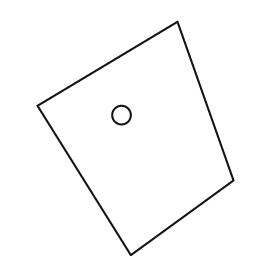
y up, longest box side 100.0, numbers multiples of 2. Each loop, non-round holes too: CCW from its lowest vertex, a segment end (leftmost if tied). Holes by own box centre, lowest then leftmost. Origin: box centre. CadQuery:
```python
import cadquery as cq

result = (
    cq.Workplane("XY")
    .moveTo(-2.0, -50.0)
    .lineTo(42.0, -18.0)
    .lineTo(18.0, 50.0)
    .lineTo(-42.0, 14.0)
    .close()
    .moveTo(-6.0, 10.0)
    .circle(4.0)
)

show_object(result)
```